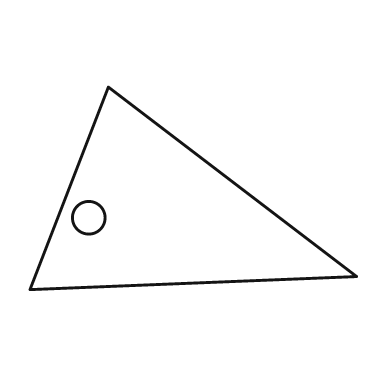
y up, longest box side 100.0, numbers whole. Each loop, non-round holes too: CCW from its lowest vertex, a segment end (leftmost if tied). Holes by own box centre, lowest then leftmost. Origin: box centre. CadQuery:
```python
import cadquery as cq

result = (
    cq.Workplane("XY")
    .moveTo(-50.0, -31.0)
    .lineTo(50.0, -27.0)
    .lineTo(-26.0, 31.0)
    .close()
    .moveTo(-32.0, -9.0)
    .circle(5.0)
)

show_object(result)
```